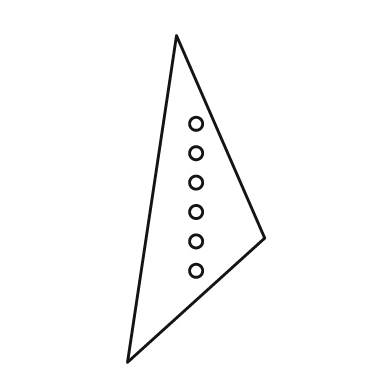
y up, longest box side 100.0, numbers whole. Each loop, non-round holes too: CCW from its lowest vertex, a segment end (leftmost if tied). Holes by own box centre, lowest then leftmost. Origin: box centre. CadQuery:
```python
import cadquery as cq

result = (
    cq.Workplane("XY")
    .moveTo(-21.0, -50.0)
    .lineTo(21.0, -12.0)
    .lineTo(-6.0, 50.0)
    .close()
    .moveTo(0.0, -22.0)
    .circle(2.0)
    .moveTo(0.0, -13.0)
    .circle(2.0)
    .moveTo(0.0, -4.0)
    .circle(2.0)
    .moveTo(0.0, 5.0)
    .circle(2.0)
    .moveTo(0.0, 14.0)
    .circle(2.0)
    .moveTo(0.0, 23.0)
    .circle(2.0)
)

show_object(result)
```